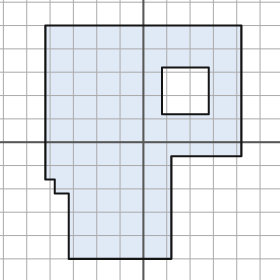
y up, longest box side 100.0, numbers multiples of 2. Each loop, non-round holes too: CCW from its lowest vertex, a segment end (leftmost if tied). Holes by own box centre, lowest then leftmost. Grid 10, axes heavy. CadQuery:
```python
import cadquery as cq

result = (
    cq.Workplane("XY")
    .moveTo(-32.0, -50.0)
    .lineTo(12.0, -50.0)
    .lineTo(12.0, -6.0)
    .lineTo(42.0, -6.0)
    .lineTo(42.0, 50.0)
    .lineTo(-42.0, 50.0)
    .lineTo(-42.0, -16.0)
    .lineTo(-38.0, -16.0)
    .lineTo(-38.0, -22.0)
    .lineTo(-32.0, -22.0)
    .close()
    .moveTo(8.0, 12.0)
    .lineTo(28.0, 12.0)
    .lineTo(28.0, 32.0)
    .lineTo(8.0, 32.0)
    .close()
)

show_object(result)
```